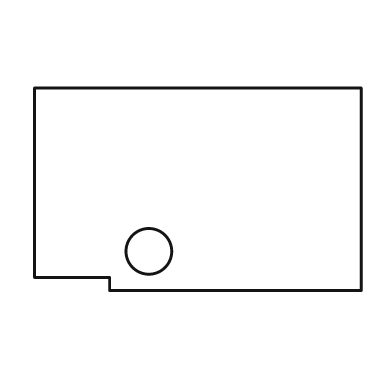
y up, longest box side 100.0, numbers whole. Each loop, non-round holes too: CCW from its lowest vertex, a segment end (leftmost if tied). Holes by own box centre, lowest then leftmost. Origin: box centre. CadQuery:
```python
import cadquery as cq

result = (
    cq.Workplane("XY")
    .moveTo(-27.0, -31.0)
    .lineTo(50.0, -31.0)
    .lineTo(50.0, 31.0)
    .lineTo(-50.0, 31.0)
    .lineTo(-50.0, -27.0)
    .lineTo(-27.0, -27.0)
    .close()
    .moveTo(-15.0, -19.0)
    .circle(7.0)
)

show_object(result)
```